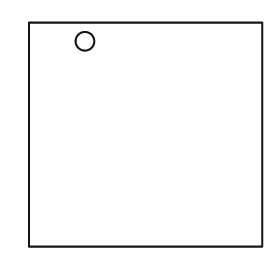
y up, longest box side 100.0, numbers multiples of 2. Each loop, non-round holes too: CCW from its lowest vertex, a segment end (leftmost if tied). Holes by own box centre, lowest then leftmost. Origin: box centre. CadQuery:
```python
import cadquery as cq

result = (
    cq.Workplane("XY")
    .moveTo(-50.0, -48.0)
    .lineTo(50.0, -48.0)
    .lineTo(50.0, 48.0)
    .lineTo(-50.0, 48.0)
    .close()
    .moveTo(-26.0, 40.0)
    .circle(4.0)
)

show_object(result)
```